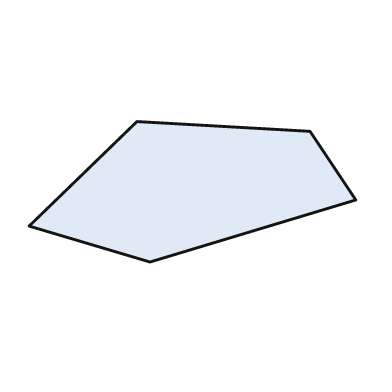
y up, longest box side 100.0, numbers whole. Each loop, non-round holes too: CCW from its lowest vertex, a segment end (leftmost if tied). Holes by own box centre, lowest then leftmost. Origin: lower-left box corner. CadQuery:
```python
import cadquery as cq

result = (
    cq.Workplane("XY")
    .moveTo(37.0, 0.0)
    .lineTo(100.0, 19.0)
    .lineTo(86.0, 40.0)
    .lineTo(33.0, 43.0)
    .lineTo(0.0, 11.0)
    .close()
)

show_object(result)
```